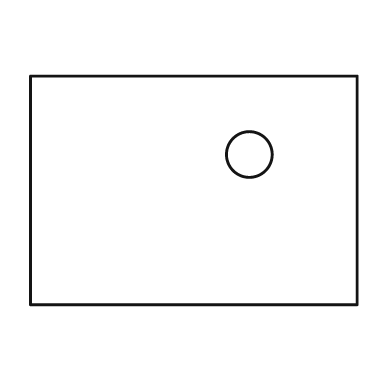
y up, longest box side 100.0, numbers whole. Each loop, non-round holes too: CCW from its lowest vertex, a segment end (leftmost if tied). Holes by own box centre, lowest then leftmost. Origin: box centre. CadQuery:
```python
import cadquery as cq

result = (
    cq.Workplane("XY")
    .moveTo(-50.0, -35.0)
    .lineTo(50.0, -35.0)
    .lineTo(50.0, 35.0)
    .lineTo(-50.0, 35.0)
    .close()
    .moveTo(17.0, 11.0)
    .circle(7.0)
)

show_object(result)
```